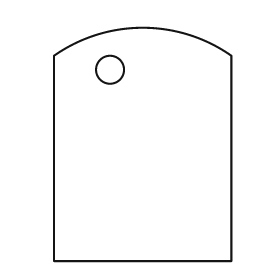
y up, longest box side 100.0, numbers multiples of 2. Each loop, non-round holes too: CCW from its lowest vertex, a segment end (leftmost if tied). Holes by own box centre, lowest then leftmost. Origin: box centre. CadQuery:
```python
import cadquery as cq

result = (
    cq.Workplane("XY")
    .moveTo(-38.0, -50.0)
    .lineTo(38.0, -50.0)
    .lineTo(38.0, 38.0)
    .threePointArc((0.0, 50.0), (-38.0, 38.0))
    .close()
    .moveTo(-14.0, 32.0)
    .circle(6.0)
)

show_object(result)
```